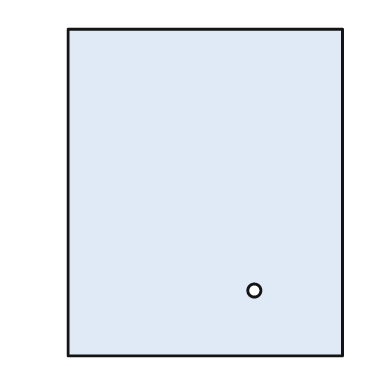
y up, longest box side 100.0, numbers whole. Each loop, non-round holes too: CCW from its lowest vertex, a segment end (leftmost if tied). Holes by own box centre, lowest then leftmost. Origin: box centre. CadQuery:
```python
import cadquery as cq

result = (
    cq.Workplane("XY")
    .moveTo(-42.0, -50.0)
    .lineTo(42.0, -50.0)
    .lineTo(42.0, 50.0)
    .lineTo(-42.0, 50.0)
    .close()
    .moveTo(15.0, -30.0)
    .circle(2.0)
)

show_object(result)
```